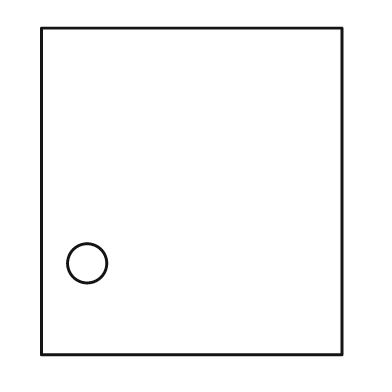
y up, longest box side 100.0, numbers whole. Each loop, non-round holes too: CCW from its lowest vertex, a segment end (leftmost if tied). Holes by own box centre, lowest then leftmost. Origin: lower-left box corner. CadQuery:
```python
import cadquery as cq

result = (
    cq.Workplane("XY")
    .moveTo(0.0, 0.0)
    .lineTo(92.0, 0.0)
    .lineTo(92.0, 100.0)
    .lineTo(0.0, 100.0)
    .close()
    .moveTo(14.0, 28.0)
    .circle(6.0)
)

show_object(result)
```